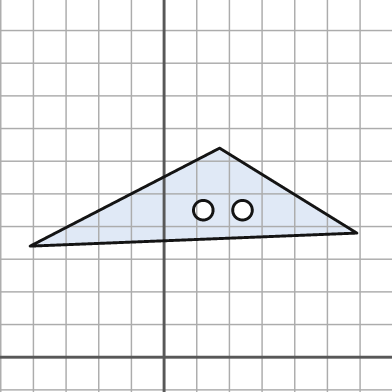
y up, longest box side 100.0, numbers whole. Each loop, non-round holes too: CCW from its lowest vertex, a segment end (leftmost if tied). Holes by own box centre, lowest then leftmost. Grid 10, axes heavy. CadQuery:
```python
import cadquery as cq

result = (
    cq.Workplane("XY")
    .moveTo(-41.0, 34.0)
    .lineTo(59.0, 38.0)
    .lineTo(17.0, 64.0)
    .close()
    .moveTo(12.0, 45.0)
    .circle(3.0)
    .moveTo(24.0, 45.0)
    .circle(3.0)
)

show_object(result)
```